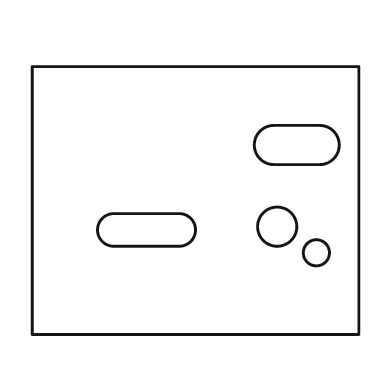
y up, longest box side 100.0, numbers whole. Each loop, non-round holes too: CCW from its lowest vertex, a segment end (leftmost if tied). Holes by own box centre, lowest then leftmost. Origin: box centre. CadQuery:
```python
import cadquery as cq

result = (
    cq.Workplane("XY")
    .moveTo(-50.0, -41.0)
    .lineTo(50.0, -41.0)
    .lineTo(50.0, 41.0)
    .lineTo(-50.0, 41.0)
    .close()
    .moveTo(37.0, -16.0)
    .circle(4.0)
    .moveTo(-25.0, -14.0)
    .lineTo(-5.0, -14.0)
    .threePointArc((0.0, -9.0), (-5.0, -4.0))
    .lineTo(-25.0, -4.0)
    .threePointArc((-30.0, -9.0), (-25.0, -14.0))
    .close()
    .moveTo(25.0, -8.0)
    .circle(6.0)
    .moveTo(24.0, 11.0)
    .lineTo(38.0, 11.0)
    .threePointArc((44.0, 17.0), (38.0, 23.0))
    .lineTo(24.0, 23.0)
    .threePointArc((18.0, 17.0), (24.0, 11.0))
    .close()
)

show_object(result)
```